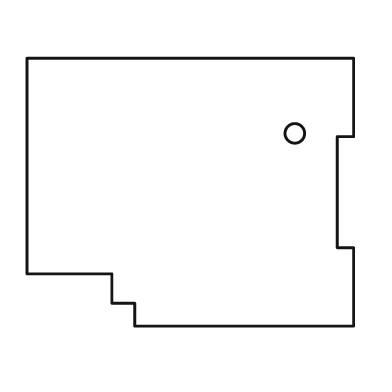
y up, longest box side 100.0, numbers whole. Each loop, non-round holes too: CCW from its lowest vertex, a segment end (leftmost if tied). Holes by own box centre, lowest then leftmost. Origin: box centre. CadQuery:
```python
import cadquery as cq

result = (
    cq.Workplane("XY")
    .moveTo(-17.0, -41.0)
    .lineTo(50.0, -41.0)
    .lineTo(50.0, -17.0)
    .lineTo(45.0, -17.0)
    .lineTo(45.0, 17.0)
    .lineTo(50.0, 17.0)
    .lineTo(50.0, 41.0)
    .lineTo(-50.0, 41.0)
    .lineTo(-50.0, -25.0)
    .lineTo(-24.0, -25.0)
    .lineTo(-24.0, -34.0)
    .lineTo(-17.0, -34.0)
    .close()
    .moveTo(32.0, 18.0)
    .circle(3.0)
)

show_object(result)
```